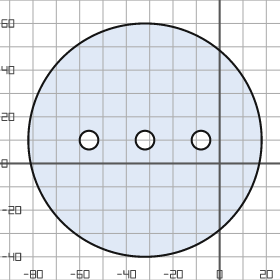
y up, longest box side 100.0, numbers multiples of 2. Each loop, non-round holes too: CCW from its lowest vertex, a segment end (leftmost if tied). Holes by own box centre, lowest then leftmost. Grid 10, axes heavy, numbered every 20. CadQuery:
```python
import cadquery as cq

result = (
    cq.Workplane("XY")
    .moveTo(-32.0, 10.0)
    .circle(50.0)
    .moveTo(-56.0, 10.0)
    .circle(4.0)
    .moveTo(-32.0, 10.0)
    .circle(4.0)
    .moveTo(-8.0, 10.0)
    .circle(4.0)
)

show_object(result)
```